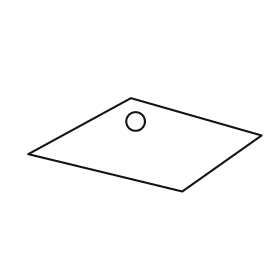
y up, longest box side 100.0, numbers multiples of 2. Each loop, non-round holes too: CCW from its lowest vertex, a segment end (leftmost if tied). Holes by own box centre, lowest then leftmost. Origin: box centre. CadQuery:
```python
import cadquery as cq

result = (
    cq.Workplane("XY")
    .moveTo(16.0, -20.0)
    .lineTo(50.0, 4.0)
    .lineTo(-6.0, 20.0)
    .lineTo(-50.0, -4.0)
    .close()
    .moveTo(-4.0, 10.0)
    .circle(4.0)
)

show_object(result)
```